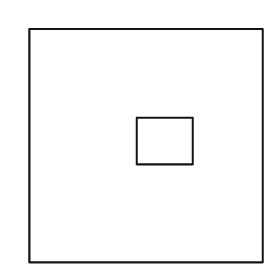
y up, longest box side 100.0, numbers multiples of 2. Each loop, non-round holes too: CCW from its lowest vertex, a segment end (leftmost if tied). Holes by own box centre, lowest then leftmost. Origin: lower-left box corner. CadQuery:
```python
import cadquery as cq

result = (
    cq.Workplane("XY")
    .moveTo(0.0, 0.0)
    .lineTo(100.0, 0.0)
    .lineTo(100.0, 100.0)
    .lineTo(0.0, 100.0)
    .close()
    .moveTo(46.0, 42.0)
    .lineTo(70.0, 42.0)
    .lineTo(70.0, 62.0)
    .lineTo(46.0, 62.0)
    .close()
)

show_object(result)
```